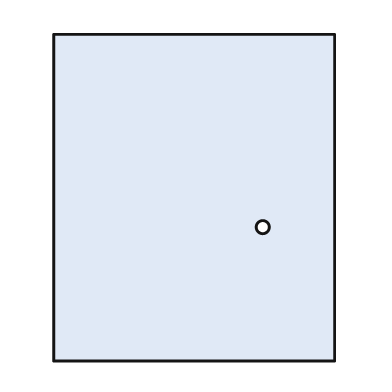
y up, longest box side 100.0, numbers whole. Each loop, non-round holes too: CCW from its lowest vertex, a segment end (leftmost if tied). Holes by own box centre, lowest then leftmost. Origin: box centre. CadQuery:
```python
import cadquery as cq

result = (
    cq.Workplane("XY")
    .moveTo(-43.0, -50.0)
    .lineTo(43.0, -50.0)
    .lineTo(43.0, 50.0)
    .lineTo(-43.0, 50.0)
    .close()
    .moveTo(21.0, -9.0)
    .circle(2.0)
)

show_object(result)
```